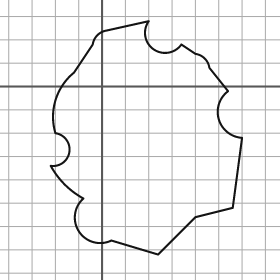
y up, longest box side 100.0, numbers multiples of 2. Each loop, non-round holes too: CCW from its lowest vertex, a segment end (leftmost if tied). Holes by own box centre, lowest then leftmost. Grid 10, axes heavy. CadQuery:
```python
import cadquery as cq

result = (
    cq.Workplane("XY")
    .moveTo(24.0, -72.0)
    .lineTo(40.0, -56.0)
    .lineTo(56.0, -52.0)
    .lineTo(60.0, -22.0)
    .threePointArc((50.0, -14.0), (54.0, -2.0))
    .lineTo(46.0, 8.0)
    .threePointArc((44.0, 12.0), (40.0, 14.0))
    .lineTo(34.0, 18.0)
    .threePointArc((22.0, 16.0), (20.0, 28.0))
    .lineTo(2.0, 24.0)
    .threePointArc((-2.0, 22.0), (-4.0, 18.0))
    .lineTo(-12.0, 6.0)
    .threePointArc((-20.0, -6.0), (-20.0, -20.0))
    .threePointArc((-14.0, -28.0), (-22.0, -34.0))
    .threePointArc((-16.0, -42.0), (-8.0, -48.0))
    .threePointArc((-10.0, -62.0), (4.0, -66.0))
    .close()
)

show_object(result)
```